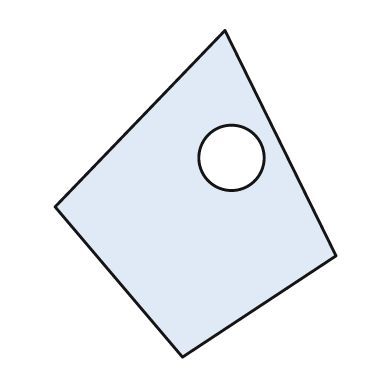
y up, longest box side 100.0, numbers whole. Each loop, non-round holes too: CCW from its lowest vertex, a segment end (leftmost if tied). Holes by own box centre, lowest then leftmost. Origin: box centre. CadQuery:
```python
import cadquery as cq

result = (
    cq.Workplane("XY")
    .moveTo(-4.0, -50.0)
    .lineTo(43.0, -19.0)
    .lineTo(9.0, 50.0)
    .lineTo(-43.0, -4.0)
    .close()
    .moveTo(11.0, 11.0)
    .circle(10.0)
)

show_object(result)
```